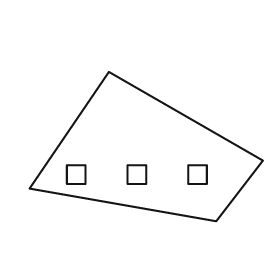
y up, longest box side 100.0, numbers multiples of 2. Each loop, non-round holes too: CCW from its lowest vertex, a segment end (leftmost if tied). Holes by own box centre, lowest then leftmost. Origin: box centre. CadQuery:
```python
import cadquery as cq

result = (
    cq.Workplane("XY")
    .moveTo(30.0, -32.0)
    .lineTo(50.0, -6.0)
    .lineTo(-16.0, 32.0)
    .lineTo(-50.0, -18.0)
    .close()
    .moveTo(-34.0, -16.0)
    .lineTo(-26.0, -16.0)
    .lineTo(-26.0, -8.0)
    .lineTo(-34.0, -8.0)
    .close()
    .moveTo(-8.0, -16.0)
    .lineTo(0.0, -16.0)
    .lineTo(0.0, -8.0)
    .lineTo(-8.0, -8.0)
    .close()
    .moveTo(18.0, -16.0)
    .lineTo(26.0, -16.0)
    .lineTo(26.0, -8.0)
    .lineTo(18.0, -8.0)
    .close()
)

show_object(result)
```